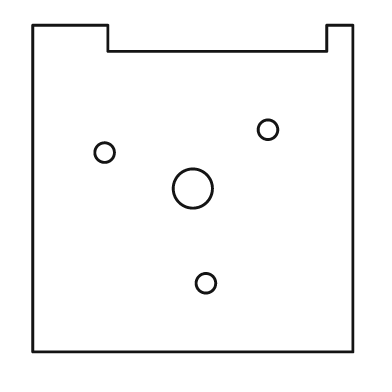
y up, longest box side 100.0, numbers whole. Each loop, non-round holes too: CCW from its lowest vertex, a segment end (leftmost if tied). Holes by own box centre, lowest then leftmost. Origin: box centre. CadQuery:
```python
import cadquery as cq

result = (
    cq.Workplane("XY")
    .moveTo(-49.0, -50.0)
    .lineTo(49.0, -50.0)
    .lineTo(49.0, 50.0)
    .lineTo(41.0, 50.0)
    .lineTo(41.0, 42.0)
    .lineTo(-26.0, 42.0)
    .lineTo(-26.0, 50.0)
    .lineTo(-49.0, 50.0)
    .close()
    .moveTo(4.0, -29.0)
    .circle(3.0)
    .moveTo(0.0, 0.0)
    .circle(6.0)
    .moveTo(-27.0, 11.0)
    .circle(3.0)
    .moveTo(23.0, 18.0)
    .circle(3.0)
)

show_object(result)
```